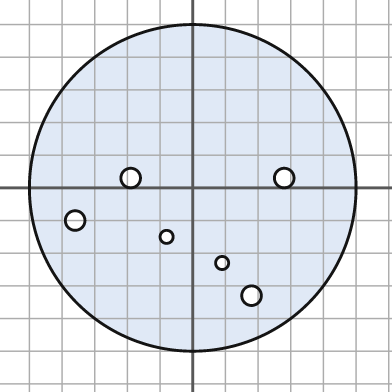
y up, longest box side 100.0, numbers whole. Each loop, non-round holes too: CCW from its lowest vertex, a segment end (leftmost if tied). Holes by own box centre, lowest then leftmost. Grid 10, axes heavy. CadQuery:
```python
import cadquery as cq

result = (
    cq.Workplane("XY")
    .moveTo(0.0, 0.0)
    .circle(50.0)
    .moveTo(18.0, -33.0)
    .circle(3.0)
    .moveTo(9.0, -23.0)
    .circle(2.0)
    .moveTo(-8.0, -15.0)
    .circle(2.0)
    .moveTo(-36.0, -10.0)
    .circle(3.0)
    .moveTo(-19.0, 3.0)
    .circle(3.0)
    .moveTo(28.0, 3.0)
    .circle(3.0)
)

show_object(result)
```